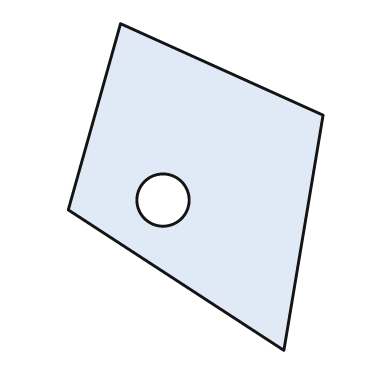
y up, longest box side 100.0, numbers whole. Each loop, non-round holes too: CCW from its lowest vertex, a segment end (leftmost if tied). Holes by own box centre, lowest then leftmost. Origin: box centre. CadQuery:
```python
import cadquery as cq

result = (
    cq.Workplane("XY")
    .moveTo(27.0, -50.0)
    .lineTo(39.0, 22.0)
    .lineTo(-23.0, 50.0)
    .lineTo(-39.0, -7.0)
    .close()
    .moveTo(-10.0, -4.0)
    .circle(8.0)
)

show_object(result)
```